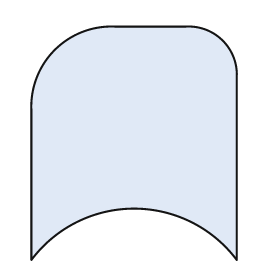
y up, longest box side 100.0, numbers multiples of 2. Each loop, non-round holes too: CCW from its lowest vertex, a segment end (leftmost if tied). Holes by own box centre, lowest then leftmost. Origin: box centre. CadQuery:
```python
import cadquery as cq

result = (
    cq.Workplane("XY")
    .moveTo(-44.0, -50.0)
    .threePointArc((0.0, -28.0), (44.0, -50.0))
    .lineTo(44.0, 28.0)
    .threePointArc((38.0, 44.0), (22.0, 50.0))
    .lineTo(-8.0, 50.0)
    .threePointArc((-34.0, 40.0), (-44.0, 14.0))
    .close()
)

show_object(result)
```